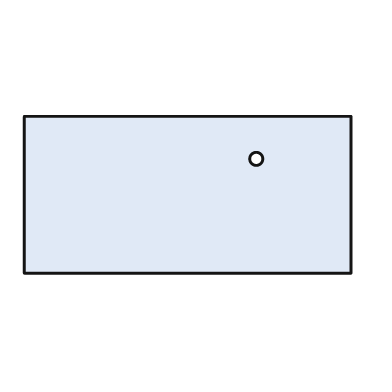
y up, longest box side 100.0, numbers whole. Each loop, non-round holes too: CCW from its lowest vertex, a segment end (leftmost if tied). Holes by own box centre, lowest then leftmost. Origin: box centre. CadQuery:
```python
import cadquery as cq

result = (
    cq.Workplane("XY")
    .moveTo(-50.0, -24.0)
    .lineTo(50.0, -24.0)
    .lineTo(50.0, 24.0)
    .lineTo(-50.0, 24.0)
    .close()
    .moveTo(21.0, 11.0)
    .circle(2.0)
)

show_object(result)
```